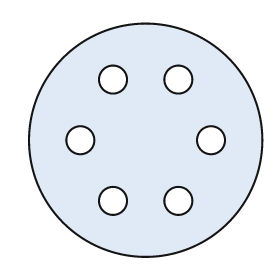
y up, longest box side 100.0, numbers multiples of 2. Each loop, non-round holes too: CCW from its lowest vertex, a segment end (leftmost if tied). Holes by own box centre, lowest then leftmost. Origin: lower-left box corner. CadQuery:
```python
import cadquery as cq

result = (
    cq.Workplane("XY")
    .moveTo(50.0, 50.0)
    .circle(50.0)
    .moveTo(36.0, 24.0)
    .circle(6.0)
    .moveTo(64.0, 24.0)
    .circle(6.0)
    .moveTo(22.0, 50.0)
    .circle(6.0)
    .moveTo(78.0, 50.0)
    .circle(6.0)
    .moveTo(36.0, 76.0)
    .circle(6.0)
    .moveTo(64.0, 76.0)
    .circle(6.0)
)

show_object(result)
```